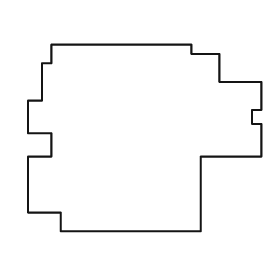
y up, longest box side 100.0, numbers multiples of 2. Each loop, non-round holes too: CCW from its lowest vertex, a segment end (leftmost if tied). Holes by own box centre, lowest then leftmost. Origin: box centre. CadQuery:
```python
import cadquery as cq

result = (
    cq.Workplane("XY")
    .moveTo(-36.0, -40.0)
    .lineTo(24.0, -40.0)
    .lineTo(24.0, -8.0)
    .lineTo(50.0, -8.0)
    .lineTo(50.0, 6.0)
    .lineTo(46.0, 6.0)
    .lineTo(46.0, 12.0)
    .lineTo(50.0, 12.0)
    .lineTo(50.0, 24.0)
    .lineTo(32.0, 24.0)
    .lineTo(32.0, 36.0)
    .lineTo(20.0, 36.0)
    .lineTo(20.0, 40.0)
    .lineTo(-40.0, 40.0)
    .lineTo(-40.0, 32.0)
    .lineTo(-44.0, 32.0)
    .lineTo(-44.0, 16.0)
    .lineTo(-50.0, 16.0)
    .lineTo(-50.0, 2.0)
    .lineTo(-40.0, 2.0)
    .lineTo(-40.0, -8.0)
    .lineTo(-50.0, -8.0)
    .lineTo(-50.0, -32.0)
    .lineTo(-36.0, -32.0)
    .close()
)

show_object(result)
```